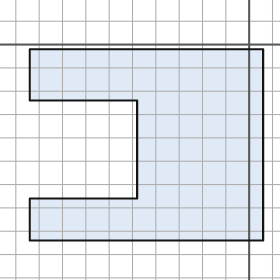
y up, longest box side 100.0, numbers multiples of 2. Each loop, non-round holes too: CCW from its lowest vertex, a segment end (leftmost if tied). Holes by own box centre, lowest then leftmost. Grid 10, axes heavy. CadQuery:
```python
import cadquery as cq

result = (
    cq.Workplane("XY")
    .moveTo(-94.0, -84.0)
    .lineTo(6.0, -84.0)
    .lineTo(6.0, -2.0)
    .lineTo(-94.0, -2.0)
    .lineTo(-94.0, -24.0)
    .lineTo(-48.0, -24.0)
    .lineTo(-48.0, -66.0)
    .lineTo(-94.0, -66.0)
    .close()
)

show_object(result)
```